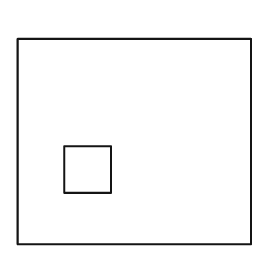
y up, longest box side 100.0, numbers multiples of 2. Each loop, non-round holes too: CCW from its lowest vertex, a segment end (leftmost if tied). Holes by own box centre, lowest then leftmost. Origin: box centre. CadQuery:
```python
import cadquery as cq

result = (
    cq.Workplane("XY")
    .moveTo(-50.0, -44.0)
    .lineTo(50.0, -44.0)
    .lineTo(50.0, 44.0)
    .lineTo(-50.0, 44.0)
    .close()
    .moveTo(-30.0, -22.0)
    .lineTo(-10.0, -22.0)
    .lineTo(-10.0, -2.0)
    .lineTo(-30.0, -2.0)
    .close()
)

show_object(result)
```